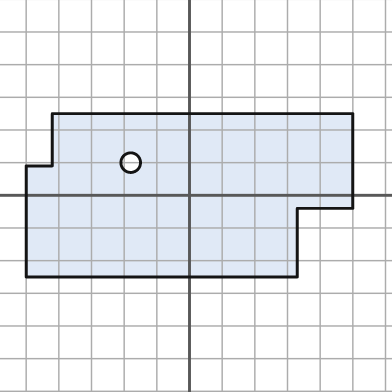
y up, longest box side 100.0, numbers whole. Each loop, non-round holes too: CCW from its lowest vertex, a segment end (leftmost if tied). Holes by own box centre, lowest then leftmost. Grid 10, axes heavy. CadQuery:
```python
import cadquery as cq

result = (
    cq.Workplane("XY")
    .moveTo(-50.0, -25.0)
    .lineTo(33.0, -25.0)
    .lineTo(33.0, -4.0)
    .lineTo(50.0, -4.0)
    .lineTo(50.0, 25.0)
    .lineTo(-42.0, 25.0)
    .lineTo(-42.0, 9.0)
    .lineTo(-50.0, 9.0)
    .close()
    .moveTo(-18.0, 10.0)
    .circle(3.0)
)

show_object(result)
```